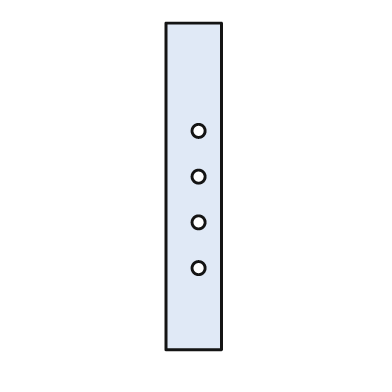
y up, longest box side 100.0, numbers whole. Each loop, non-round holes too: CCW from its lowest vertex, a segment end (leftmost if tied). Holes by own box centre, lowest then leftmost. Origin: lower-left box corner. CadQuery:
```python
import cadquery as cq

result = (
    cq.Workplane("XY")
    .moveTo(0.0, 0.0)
    .lineTo(17.0, 0.0)
    .lineTo(17.0, 100.0)
    .lineTo(0.0, 100.0)
    .close()
    .moveTo(10.0, 25.0)
    .circle(2.0)
    .moveTo(10.0, 39.0)
    .circle(2.0)
    .moveTo(10.0, 53.0)
    .circle(2.0)
    .moveTo(10.0, 67.0)
    .circle(2.0)
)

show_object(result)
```